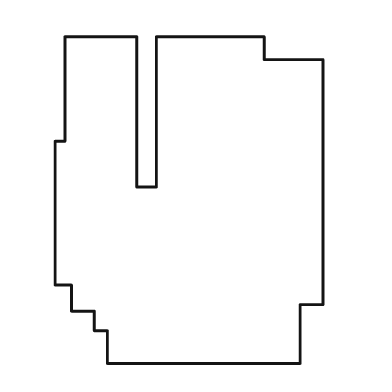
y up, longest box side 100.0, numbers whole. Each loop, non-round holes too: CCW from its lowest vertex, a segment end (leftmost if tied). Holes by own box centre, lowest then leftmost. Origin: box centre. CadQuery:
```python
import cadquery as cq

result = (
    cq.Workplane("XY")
    .moveTo(-25.0, -50.0)
    .lineTo(34.0, -50.0)
    .lineTo(34.0, -32.0)
    .lineTo(41.0, -32.0)
    .lineTo(41.0, 43.0)
    .lineTo(23.0, 43.0)
    .lineTo(23.0, 50.0)
    .lineTo(-10.0, 50.0)
    .lineTo(-10.0, 4.0)
    .lineTo(-16.0, 4.0)
    .lineTo(-16.0, 50.0)
    .lineTo(-38.0, 50.0)
    .lineTo(-38.0, 18.0)
    .lineTo(-41.0, 18.0)
    .lineTo(-41.0, -26.0)
    .lineTo(-36.0, -26.0)
    .lineTo(-36.0, -34.0)
    .lineTo(-29.0, -34.0)
    .lineTo(-29.0, -40.0)
    .lineTo(-25.0, -40.0)
    .close()
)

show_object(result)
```